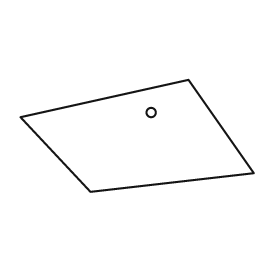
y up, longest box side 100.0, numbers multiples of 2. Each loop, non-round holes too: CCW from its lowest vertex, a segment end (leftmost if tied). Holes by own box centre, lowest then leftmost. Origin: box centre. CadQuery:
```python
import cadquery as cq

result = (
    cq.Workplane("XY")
    .moveTo(-20.0, -24.0)
    .lineTo(50.0, -16.0)
    .lineTo(22.0, 24.0)
    .lineTo(-50.0, 8.0)
    .close()
    .moveTo(6.0, 10.0)
    .circle(2.0)
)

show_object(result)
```